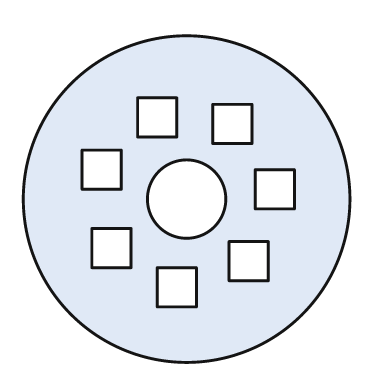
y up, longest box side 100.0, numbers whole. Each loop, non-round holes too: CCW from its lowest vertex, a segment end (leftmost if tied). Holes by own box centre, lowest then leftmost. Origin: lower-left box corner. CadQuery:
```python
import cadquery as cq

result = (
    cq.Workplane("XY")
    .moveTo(50.0, 50.0)
    .circle(50.0)
    .moveTo(41.0, 17.0)
    .lineTo(53.0, 17.0)
    .lineTo(53.0, 29.0)
    .lineTo(41.0, 29.0)
    .close()
    .moveTo(63.0, 25.0)
    .lineTo(75.0, 25.0)
    .lineTo(75.0, 37.0)
    .lineTo(63.0, 37.0)
    .close()
    .moveTo(21.0, 29.0)
    .lineTo(33.0, 29.0)
    .lineTo(33.0, 41.0)
    .lineTo(21.0, 41.0)
    .close()
    .moveTo(50.0, 50.0)
    .circle(12.0)
    .moveTo(71.0, 47.0)
    .lineTo(83.0, 47.0)
    .lineTo(83.0, 59.0)
    .lineTo(71.0, 59.0)
    .close()
    .moveTo(18.0, 53.0)
    .lineTo(30.0, 53.0)
    .lineTo(30.0, 65.0)
    .lineTo(18.0, 65.0)
    .close()
    .moveTo(58.0, 67.0)
    .lineTo(70.0, 67.0)
    .lineTo(70.0, 79.0)
    .lineTo(58.0, 79.0)
    .close()
    .moveTo(35.0, 69.0)
    .lineTo(47.0, 69.0)
    .lineTo(47.0, 81.0)
    .lineTo(35.0, 81.0)
    .close()
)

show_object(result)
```